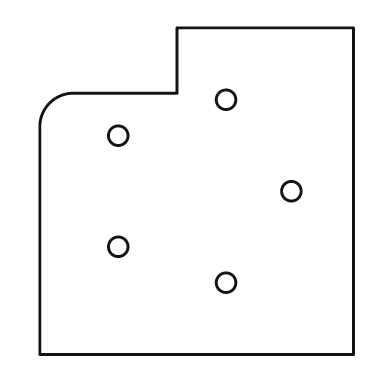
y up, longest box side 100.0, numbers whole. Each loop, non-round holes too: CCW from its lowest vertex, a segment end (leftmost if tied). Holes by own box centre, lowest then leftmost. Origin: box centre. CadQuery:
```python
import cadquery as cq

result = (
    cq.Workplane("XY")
    .moveTo(-48.0, -50.0)
    .lineTo(48.0, -50.0)
    .lineTo(48.0, 50.0)
    .lineTo(-6.0, 50.0)
    .lineTo(-6.0, 30.0)
    .lineTo(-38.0, 30.0)
    .threePointArc((-45.0, 27.0), (-48.0, 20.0))
    .close()
    .moveTo(9.0, -28.0)
    .circle(3.0)
    .moveTo(-24.0, -17.0)
    .circle(3.0)
    .moveTo(29.0, 0.0)
    .circle(3.0)
    .moveTo(-24.0, 17.0)
    .circle(3.0)
    .moveTo(9.0, 28.0)
    .circle(3.0)
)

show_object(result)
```